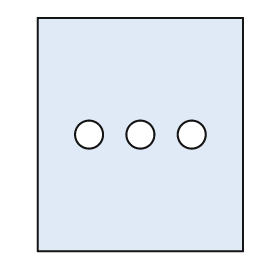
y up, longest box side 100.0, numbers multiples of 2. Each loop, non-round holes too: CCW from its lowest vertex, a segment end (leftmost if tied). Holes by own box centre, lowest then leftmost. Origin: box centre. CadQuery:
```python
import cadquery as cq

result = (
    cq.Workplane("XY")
    .moveTo(-44.0, -50.0)
    .lineTo(44.0, -50.0)
    .lineTo(44.0, 50.0)
    .lineTo(-44.0, 50.0)
    .close()
    .moveTo(-22.0, 0.0)
    .circle(6.0)
    .moveTo(0.0, 0.0)
    .circle(6.0)
    .moveTo(22.0, 0.0)
    .circle(6.0)
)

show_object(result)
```